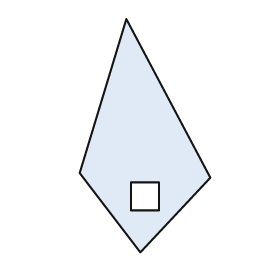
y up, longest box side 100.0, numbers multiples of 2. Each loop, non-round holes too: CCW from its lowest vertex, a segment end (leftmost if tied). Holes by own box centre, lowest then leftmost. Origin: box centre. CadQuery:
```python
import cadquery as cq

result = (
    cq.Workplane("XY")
    .moveTo(-2.0, -50.0)
    .lineTo(28.0, -18.0)
    .lineTo(-8.0, 50.0)
    .lineTo(-28.0, -16.0)
    .close()
    .moveTo(-6.0, -32.0)
    .lineTo(6.0, -32.0)
    .lineTo(6.0, -20.0)
    .lineTo(-6.0, -20.0)
    .close()
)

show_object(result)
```